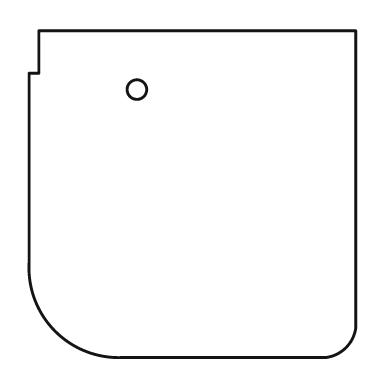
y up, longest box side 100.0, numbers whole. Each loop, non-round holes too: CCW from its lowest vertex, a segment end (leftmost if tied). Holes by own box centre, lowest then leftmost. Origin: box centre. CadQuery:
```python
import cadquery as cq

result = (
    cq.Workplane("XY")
    .moveTo(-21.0, -50.0)
    .lineTo(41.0, -50.0)
    .threePointArc((47.0, -47.0), (50.0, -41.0))
    .lineTo(50.0, 50.0)
    .lineTo(-47.0, 50.0)
    .lineTo(-47.0, 37.0)
    .lineTo(-50.0, 37.0)
    .lineTo(-50.0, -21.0)
    .threePointArc((-42.0, -42.0), (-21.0, -50.0))
    .close()
    .moveTo(-17.0, 32.0)
    .circle(3.0)
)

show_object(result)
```